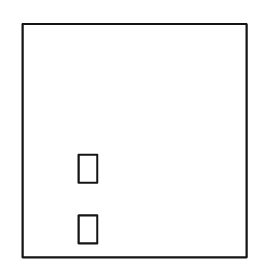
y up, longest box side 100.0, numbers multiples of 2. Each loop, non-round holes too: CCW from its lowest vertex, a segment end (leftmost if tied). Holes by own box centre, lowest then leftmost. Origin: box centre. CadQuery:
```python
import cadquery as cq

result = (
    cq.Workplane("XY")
    .moveTo(-48.0, -50.0)
    .lineTo(48.0, -50.0)
    .lineTo(48.0, 50.0)
    .lineTo(-48.0, 50.0)
    .close()
    .moveTo(-24.0, -44.0)
    .lineTo(-16.0, -44.0)
    .lineTo(-16.0, -32.0)
    .lineTo(-24.0, -32.0)
    .close()
    .moveTo(-24.0, -18.0)
    .lineTo(-16.0, -18.0)
    .lineTo(-16.0, -6.0)
    .lineTo(-24.0, -6.0)
    .close()
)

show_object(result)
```